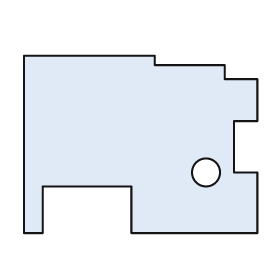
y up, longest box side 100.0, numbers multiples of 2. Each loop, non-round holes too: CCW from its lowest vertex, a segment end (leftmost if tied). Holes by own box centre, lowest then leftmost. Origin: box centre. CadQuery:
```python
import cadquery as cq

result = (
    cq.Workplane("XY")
    .moveTo(-50.0, -38.0)
    .lineTo(-42.0, -38.0)
    .lineTo(-42.0, -18.0)
    .lineTo(-4.0, -18.0)
    .lineTo(-4.0, -38.0)
    .lineTo(50.0, -38.0)
    .lineTo(50.0, -12.0)
    .lineTo(40.0, -12.0)
    .lineTo(40.0, 10.0)
    .lineTo(50.0, 10.0)
    .lineTo(50.0, 28.0)
    .lineTo(36.0, 28.0)
    .lineTo(36.0, 34.0)
    .lineTo(6.0, 34.0)
    .lineTo(6.0, 38.0)
    .lineTo(-50.0, 38.0)
    .close()
    .moveTo(28.0, -12.0)
    .circle(6.0)
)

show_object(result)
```